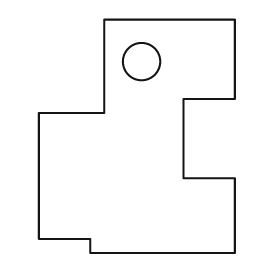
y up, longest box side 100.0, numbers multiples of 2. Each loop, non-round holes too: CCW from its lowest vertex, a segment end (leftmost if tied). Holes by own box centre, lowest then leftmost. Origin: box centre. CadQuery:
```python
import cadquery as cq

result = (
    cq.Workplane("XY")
    .moveTo(-20.0, -50.0)
    .lineTo(42.0, -50.0)
    .lineTo(42.0, -18.0)
    .lineTo(20.0, -18.0)
    .lineTo(20.0, 16.0)
    .lineTo(42.0, 16.0)
    .lineTo(42.0, 50.0)
    .lineTo(-14.0, 50.0)
    .lineTo(-14.0, 10.0)
    .lineTo(-42.0, 10.0)
    .lineTo(-42.0, -44.0)
    .lineTo(-20.0, -44.0)
    .close()
    .moveTo(2.0, 32.0)
    .circle(8.0)
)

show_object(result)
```